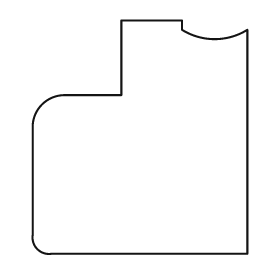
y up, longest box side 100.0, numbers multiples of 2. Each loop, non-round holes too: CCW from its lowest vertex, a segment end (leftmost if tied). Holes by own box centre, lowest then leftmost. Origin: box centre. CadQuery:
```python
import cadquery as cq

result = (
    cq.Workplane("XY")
    .moveTo(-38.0, -50.0)
    .lineTo(46.0, -50.0)
    .lineTo(46.0, 46.0)
    .threePointArc((32.0, 42.0), (18.0, 46.0))
    .lineTo(18.0, 50.0)
    .lineTo(-8.0, 50.0)
    .lineTo(-8.0, 18.0)
    .lineTo(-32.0, 18.0)
    .threePointArc((-42.0, 14.0), (-46.0, 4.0))
    .lineTo(-46.0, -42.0)
    .threePointArc((-44.0, -48.0), (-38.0, -50.0))
    .close()
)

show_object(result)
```